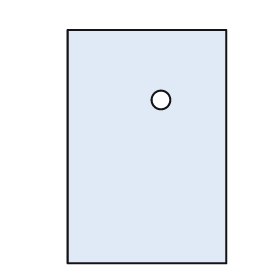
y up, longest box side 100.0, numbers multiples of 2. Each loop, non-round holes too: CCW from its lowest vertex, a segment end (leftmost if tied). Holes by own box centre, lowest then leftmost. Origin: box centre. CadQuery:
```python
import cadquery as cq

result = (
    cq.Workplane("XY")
    .moveTo(-34.0, -50.0)
    .lineTo(34.0, -50.0)
    .lineTo(34.0, 50.0)
    .lineTo(-34.0, 50.0)
    .close()
    .moveTo(6.0, 20.0)
    .circle(4.0)
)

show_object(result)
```